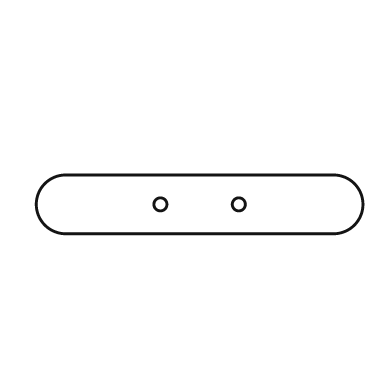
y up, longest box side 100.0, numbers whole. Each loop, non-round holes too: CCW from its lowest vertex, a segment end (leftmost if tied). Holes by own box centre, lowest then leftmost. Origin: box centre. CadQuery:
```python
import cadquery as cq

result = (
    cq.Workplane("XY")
    .moveTo(-41.0, -9.0)
    .lineTo(41.0, -9.0)
    .threePointArc((50.0, 0.0), (41.0, 9.0))
    .lineTo(-41.0, 9.0)
    .threePointArc((-50.0, 0.0), (-41.0, -9.0))
    .close()
    .moveTo(-12.0, 0.0)
    .circle(2.0)
    .moveTo(12.0, 0.0)
    .circle(2.0)
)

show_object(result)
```